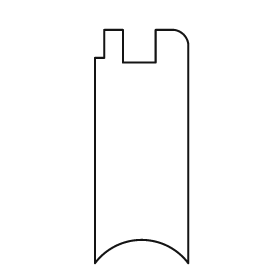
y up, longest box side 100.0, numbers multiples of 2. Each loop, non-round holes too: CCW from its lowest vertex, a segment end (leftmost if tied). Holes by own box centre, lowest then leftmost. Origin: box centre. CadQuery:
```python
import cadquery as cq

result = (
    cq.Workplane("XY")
    .moveTo(-20.0, -50.0)
    .threePointArc((0.0, -40.0), (20.0, -50.0))
    .lineTo(20.0, 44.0)
    .threePointArc((18.0, 48.0), (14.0, 50.0))
    .lineTo(6.0, 50.0)
    .lineTo(6.0, 36.0)
    .lineTo(-8.0, 36.0)
    .lineTo(-8.0, 50.0)
    .lineTo(-16.0, 50.0)
    .lineTo(-16.0, 38.0)
    .lineTo(-20.0, 38.0)
    .close()
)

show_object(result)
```